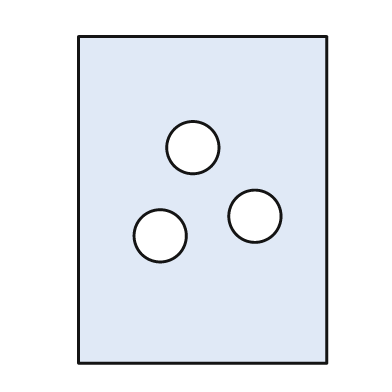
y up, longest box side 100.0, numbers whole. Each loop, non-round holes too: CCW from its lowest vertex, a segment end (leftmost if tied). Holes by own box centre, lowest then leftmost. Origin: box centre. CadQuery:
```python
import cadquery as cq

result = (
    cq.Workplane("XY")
    .moveTo(-38.0, -50.0)
    .lineTo(38.0, -50.0)
    .lineTo(38.0, 50.0)
    .lineTo(-38.0, 50.0)
    .close()
    .moveTo(-13.0, -11.0)
    .circle(8.0)
    .moveTo(16.0, -5.0)
    .circle(8.0)
    .moveTo(-3.0, 16.0)
    .circle(8.0)
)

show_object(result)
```